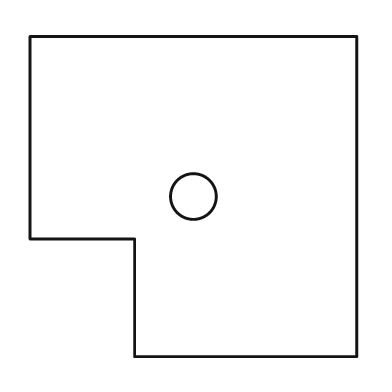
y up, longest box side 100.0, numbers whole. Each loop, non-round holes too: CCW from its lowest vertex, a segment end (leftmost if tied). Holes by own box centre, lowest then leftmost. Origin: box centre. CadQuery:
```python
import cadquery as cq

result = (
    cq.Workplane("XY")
    .moveTo(-18.0, -49.0)
    .lineTo(50.0, -49.0)
    .lineTo(50.0, 49.0)
    .lineTo(-50.0, 49.0)
    .lineTo(-50.0, -13.0)
    .lineTo(-18.0, -13.0)
    .close()
    .moveTo(0.0, 0.0)
    .circle(7.0)
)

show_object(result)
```